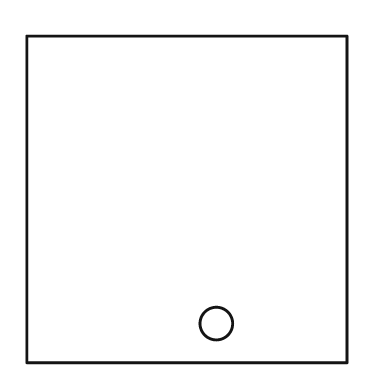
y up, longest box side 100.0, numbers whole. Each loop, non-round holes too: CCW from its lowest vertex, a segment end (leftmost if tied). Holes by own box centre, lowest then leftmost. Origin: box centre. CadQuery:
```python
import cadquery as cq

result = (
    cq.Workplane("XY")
    .moveTo(-49.0, -50.0)
    .lineTo(49.0, -50.0)
    .lineTo(49.0, 50.0)
    .lineTo(-49.0, 50.0)
    .close()
    .moveTo(9.0, -38.0)
    .circle(5.0)
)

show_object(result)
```